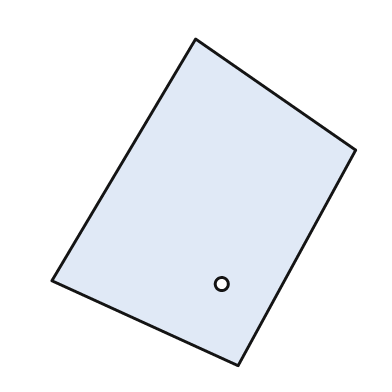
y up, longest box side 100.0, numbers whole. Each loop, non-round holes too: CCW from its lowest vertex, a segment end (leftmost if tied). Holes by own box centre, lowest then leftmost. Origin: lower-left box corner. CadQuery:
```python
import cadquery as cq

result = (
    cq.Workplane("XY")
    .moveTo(57.0, 0.0)
    .lineTo(93.0, 66.0)
    .lineTo(44.0, 100.0)
    .lineTo(0.0, 26.0)
    .close()
    .moveTo(52.0, 25.0)
    .circle(2.0)
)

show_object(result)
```